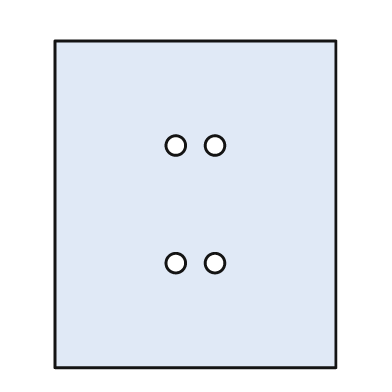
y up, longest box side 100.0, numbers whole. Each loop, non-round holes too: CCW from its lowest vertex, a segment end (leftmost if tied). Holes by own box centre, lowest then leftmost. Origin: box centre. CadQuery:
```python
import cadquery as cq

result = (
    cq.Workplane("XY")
    .moveTo(-43.0, -50.0)
    .lineTo(43.0, -50.0)
    .lineTo(43.0, 50.0)
    .lineTo(-43.0, 50.0)
    .close()
    .moveTo(-6.0, -18.0)
    .circle(3.0)
    .moveTo(6.0, -18.0)
    .circle(3.0)
    .moveTo(-6.0, 18.0)
    .circle(3.0)
    .moveTo(6.0, 18.0)
    .circle(3.0)
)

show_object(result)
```